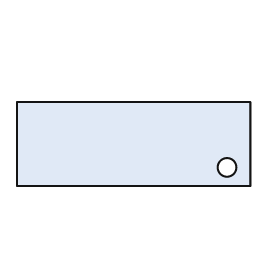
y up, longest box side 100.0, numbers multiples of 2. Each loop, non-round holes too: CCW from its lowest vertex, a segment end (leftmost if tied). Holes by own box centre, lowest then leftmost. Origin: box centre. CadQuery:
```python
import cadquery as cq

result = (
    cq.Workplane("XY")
    .moveTo(-50.0, -18.0)
    .lineTo(50.0, -18.0)
    .lineTo(50.0, 18.0)
    .lineTo(-50.0, 18.0)
    .close()
    .moveTo(40.0, -10.0)
    .circle(4.0)
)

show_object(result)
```